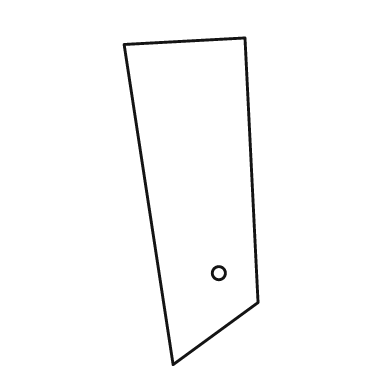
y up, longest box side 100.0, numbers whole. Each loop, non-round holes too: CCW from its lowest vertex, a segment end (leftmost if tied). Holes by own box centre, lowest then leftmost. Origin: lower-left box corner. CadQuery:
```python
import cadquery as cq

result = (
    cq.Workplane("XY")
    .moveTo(15.0, 0.0)
    .lineTo(41.0, 19.0)
    .lineTo(37.0, 100.0)
    .lineTo(0.0, 98.0)
    .close()
    .moveTo(29.0, 28.0)
    .circle(2.0)
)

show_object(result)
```